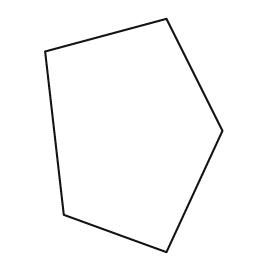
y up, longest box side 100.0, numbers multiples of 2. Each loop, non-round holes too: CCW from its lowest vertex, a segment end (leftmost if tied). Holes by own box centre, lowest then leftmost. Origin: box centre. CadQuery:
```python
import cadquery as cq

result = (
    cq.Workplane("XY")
    .moveTo(14.0, -50.0)
    .lineTo(38.0, 2.0)
    .lineTo(14.0, 50.0)
    .lineTo(-38.0, 36.0)
    .lineTo(-30.0, -34.0)
    .close()
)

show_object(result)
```